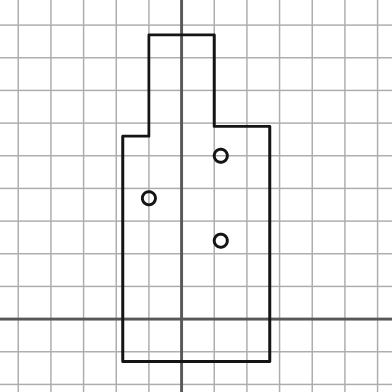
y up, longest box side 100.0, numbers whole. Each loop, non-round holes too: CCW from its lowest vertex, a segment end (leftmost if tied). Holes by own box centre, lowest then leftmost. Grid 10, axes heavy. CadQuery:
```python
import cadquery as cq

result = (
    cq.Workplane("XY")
    .moveTo(-18.0, -13.0)
    .lineTo(27.0, -13.0)
    .lineTo(27.0, 59.0)
    .lineTo(10.0, 59.0)
    .lineTo(10.0, 87.0)
    .lineTo(-10.0, 87.0)
    .lineTo(-10.0, 56.0)
    .lineTo(-18.0, 56.0)
    .close()
    .moveTo(12.0, 24.0)
    .circle(2.0)
    .moveTo(-10.0, 37.0)
    .circle(2.0)
    .moveTo(12.0, 50.0)
    .circle(2.0)
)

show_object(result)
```